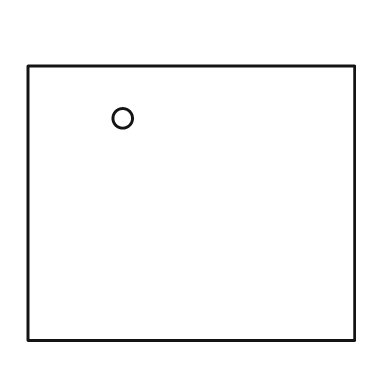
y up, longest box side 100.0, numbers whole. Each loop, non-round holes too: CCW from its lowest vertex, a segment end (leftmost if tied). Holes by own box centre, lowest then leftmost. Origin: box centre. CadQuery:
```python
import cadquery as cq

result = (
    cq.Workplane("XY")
    .moveTo(-50.0, -42.0)
    .lineTo(50.0, -42.0)
    .lineTo(50.0, 42.0)
    .lineTo(-50.0, 42.0)
    .close()
    .moveTo(-21.0, 26.0)
    .circle(3.0)
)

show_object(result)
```